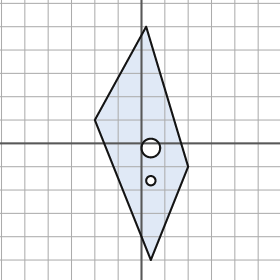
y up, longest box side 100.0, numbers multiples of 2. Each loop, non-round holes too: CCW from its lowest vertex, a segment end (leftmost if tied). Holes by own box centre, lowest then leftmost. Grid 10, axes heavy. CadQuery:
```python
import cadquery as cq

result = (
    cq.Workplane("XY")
    .moveTo(4.0, -50.0)
    .lineTo(20.0, -10.0)
    .lineTo(2.0, 50.0)
    .lineTo(-20.0, 10.0)
    .close()
    .moveTo(4.0, -16.0)
    .circle(2.0)
    .moveTo(4.0, -2.0)
    .circle(4.0)
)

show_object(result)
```